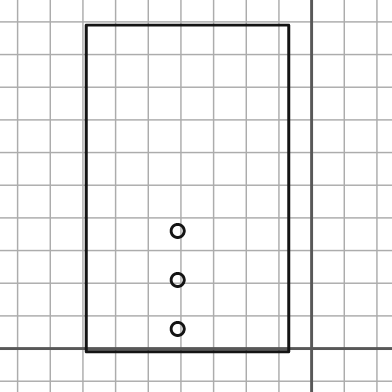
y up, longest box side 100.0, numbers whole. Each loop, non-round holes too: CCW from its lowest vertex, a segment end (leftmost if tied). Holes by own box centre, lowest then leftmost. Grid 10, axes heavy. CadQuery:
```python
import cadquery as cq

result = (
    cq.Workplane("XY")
    .moveTo(-69.0, -1.0)
    .lineTo(-7.0, -1.0)
    .lineTo(-7.0, 99.0)
    .lineTo(-69.0, 99.0)
    .close()
    .moveTo(-41.0, 6.0)
    .circle(2.0)
    .moveTo(-41.0, 21.0)
    .circle(2.0)
    .moveTo(-41.0, 36.0)
    .circle(2.0)
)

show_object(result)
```